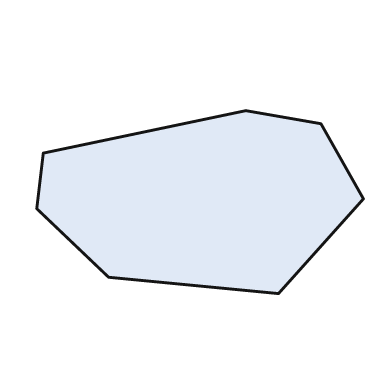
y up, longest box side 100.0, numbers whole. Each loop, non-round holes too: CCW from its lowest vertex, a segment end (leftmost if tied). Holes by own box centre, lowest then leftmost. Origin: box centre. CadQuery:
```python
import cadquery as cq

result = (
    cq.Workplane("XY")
    .moveTo(24.0, -28.0)
    .lineTo(50.0, 1.0)
    .lineTo(37.0, 24.0)
    .lineTo(14.0, 28.0)
    .lineTo(-48.0, 15.0)
    .lineTo(-50.0, -2.0)
    .lineTo(-28.0, -23.0)
    .close()
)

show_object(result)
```